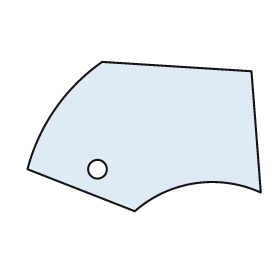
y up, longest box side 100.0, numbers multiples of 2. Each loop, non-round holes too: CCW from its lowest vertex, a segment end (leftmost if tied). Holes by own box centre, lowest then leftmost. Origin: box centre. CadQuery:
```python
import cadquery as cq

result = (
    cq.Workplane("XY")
    .moveTo(-4.0, -32.0)
    .threePointArc((22.0, -20.0), (50.0, -24.0))
    .lineTo(46.0, 28.0)
    .lineTo(-18.0, 32.0)
    .threePointArc((-38.0, 12.0), (-50.0, -14.0))
    .close()
    .moveTo(-20.0, -14.0)
    .circle(4.0)
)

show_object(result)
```